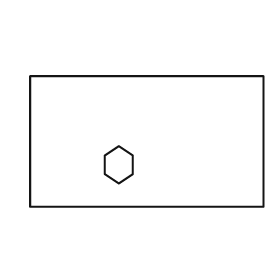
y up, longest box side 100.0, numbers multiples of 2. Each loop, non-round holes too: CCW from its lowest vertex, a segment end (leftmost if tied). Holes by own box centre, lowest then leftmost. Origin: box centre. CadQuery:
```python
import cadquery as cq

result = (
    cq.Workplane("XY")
    .moveTo(-50.0, -28.0)
    .lineTo(50.0, -28.0)
    .lineTo(50.0, 28.0)
    .lineTo(-50.0, 28.0)
    .close()
    .moveTo(-12.0, -18.0)
    .lineTo(-6.0, -14.0)
    .lineTo(-6.0, -6.0)
    .lineTo(-12.0, -2.0)
    .lineTo(-18.0, -6.0)
    .lineTo(-18.0, -14.0)
    .close()
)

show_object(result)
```